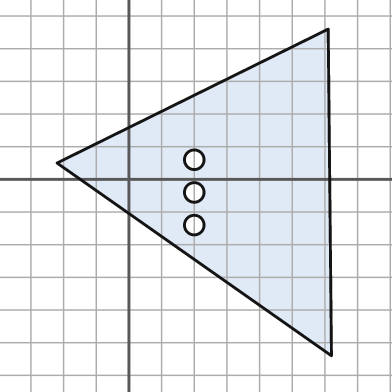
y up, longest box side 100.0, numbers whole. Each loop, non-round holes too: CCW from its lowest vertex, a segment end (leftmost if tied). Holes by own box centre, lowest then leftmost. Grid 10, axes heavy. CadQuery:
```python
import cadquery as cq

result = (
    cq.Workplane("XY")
    .moveTo(62.0, -54.0)
    .lineTo(61.0, 46.0)
    .lineTo(-22.0, 5.0)
    .close()
    .moveTo(20.0, -14.0)
    .circle(3.0)
    .moveTo(20.0, -4.0)
    .circle(3.0)
    .moveTo(20.0, 6.0)
    .circle(3.0)
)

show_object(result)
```